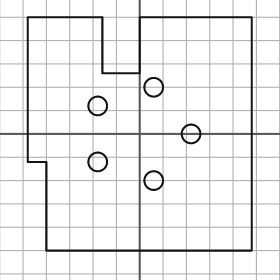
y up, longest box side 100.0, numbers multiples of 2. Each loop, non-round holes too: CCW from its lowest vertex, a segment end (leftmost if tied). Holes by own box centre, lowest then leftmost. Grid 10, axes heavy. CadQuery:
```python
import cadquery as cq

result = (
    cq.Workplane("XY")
    .moveTo(-40.0, -50.0)
    .lineTo(48.0, -50.0)
    .lineTo(48.0, 50.0)
    .lineTo(0.0, 50.0)
    .lineTo(0.0, 26.0)
    .lineTo(-16.0, 26.0)
    .lineTo(-16.0, 50.0)
    .lineTo(-48.0, 50.0)
    .lineTo(-48.0, -12.0)
    .lineTo(-40.0, -12.0)
    .close()
    .moveTo(6.0, -20.0)
    .circle(4.0)
    .moveTo(-18.0, -12.0)
    .circle(4.0)
    .moveTo(22.0, 0.0)
    .circle(4.0)
    .moveTo(-18.0, 12.0)
    .circle(4.0)
    .moveTo(6.0, 20.0)
    .circle(4.0)
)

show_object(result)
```